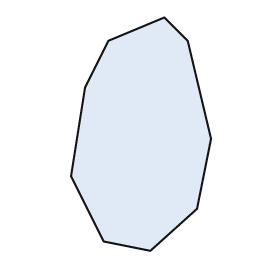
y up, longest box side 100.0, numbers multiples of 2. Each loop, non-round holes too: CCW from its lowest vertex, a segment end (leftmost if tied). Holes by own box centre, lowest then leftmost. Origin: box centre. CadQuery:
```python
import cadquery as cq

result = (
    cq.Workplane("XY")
    .moveTo(4.0, -50.0)
    .lineTo(24.0, -32.0)
    .lineTo(30.0, -2.0)
    .lineTo(20.0, 40.0)
    .lineTo(10.0, 50.0)
    .lineTo(-14.0, 40.0)
    .lineTo(-24.0, 20.0)
    .lineTo(-30.0, -18.0)
    .lineTo(-16.0, -46.0)
    .close()
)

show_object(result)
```